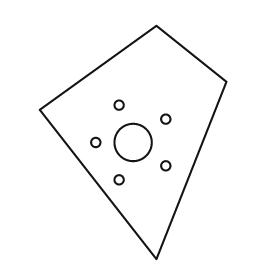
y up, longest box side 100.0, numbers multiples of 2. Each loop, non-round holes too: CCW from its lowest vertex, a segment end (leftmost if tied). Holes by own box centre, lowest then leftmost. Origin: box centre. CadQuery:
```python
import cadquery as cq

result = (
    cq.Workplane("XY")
    .moveTo(10.0, -50.0)
    .lineTo(40.0, 26.0)
    .lineTo(10.0, 50.0)
    .lineTo(-40.0, 14.0)
    .close()
    .moveTo(-6.0, -16.0)
    .circle(2.0)
    .moveTo(14.0, -10.0)
    .circle(2.0)
    .moveTo(-16.0, 0.0)
    .circle(2.0)
    .moveTo(0.0, 0.0)
    .circle(8.0)
    .moveTo(14.0, 10.0)
    .circle(2.0)
    .moveTo(-6.0, 16.0)
    .circle(2.0)
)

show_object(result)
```